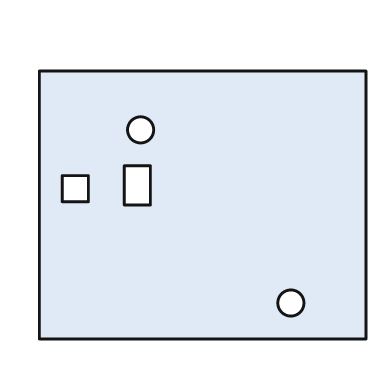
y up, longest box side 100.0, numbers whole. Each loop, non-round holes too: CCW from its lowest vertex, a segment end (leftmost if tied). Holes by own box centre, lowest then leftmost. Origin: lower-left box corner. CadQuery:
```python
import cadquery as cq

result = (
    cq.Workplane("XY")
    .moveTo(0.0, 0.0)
    .lineTo(100.0, 0.0)
    .lineTo(100.0, 82.0)
    .lineTo(0.0, 82.0)
    .close()
    .moveTo(77.0, 11.0)
    .circle(4.0)
    .moveTo(7.0, 42.0)
    .lineTo(15.0, 42.0)
    .lineTo(15.0, 50.0)
    .lineTo(7.0, 50.0)
    .close()
    .moveTo(26.0, 41.0)
    .lineTo(34.0, 41.0)
    .lineTo(34.0, 53.0)
    .lineTo(26.0, 53.0)
    .close()
    .moveTo(31.0, 64.0)
    .circle(4.0)
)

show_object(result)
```